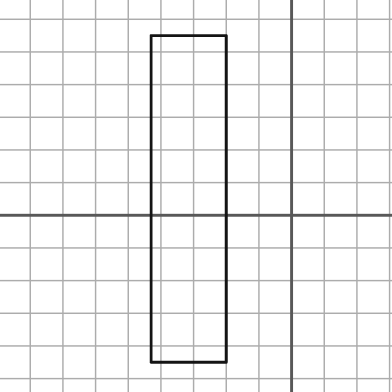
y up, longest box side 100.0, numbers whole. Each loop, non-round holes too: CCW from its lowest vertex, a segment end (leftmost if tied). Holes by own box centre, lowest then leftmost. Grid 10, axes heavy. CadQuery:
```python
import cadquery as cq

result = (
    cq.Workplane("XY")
    .moveTo(-43.0, -45.0)
    .lineTo(-20.0, -45.0)
    .lineTo(-20.0, 55.0)
    .lineTo(-43.0, 55.0)
    .close()
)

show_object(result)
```